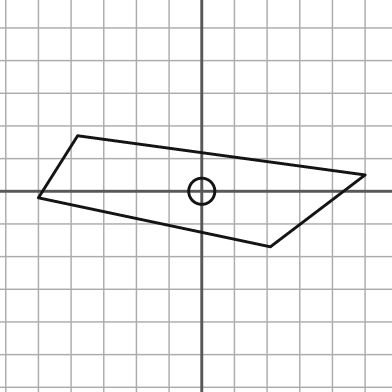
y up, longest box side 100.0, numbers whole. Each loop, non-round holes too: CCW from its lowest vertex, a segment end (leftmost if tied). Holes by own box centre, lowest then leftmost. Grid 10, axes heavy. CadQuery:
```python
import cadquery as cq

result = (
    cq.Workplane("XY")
    .moveTo(21.0, -17.0)
    .lineTo(50.0, 5.0)
    .lineTo(-38.0, 17.0)
    .lineTo(-50.0, -2.0)
    .close()
    .moveTo(0.0, 0.0)
    .circle(4.0)
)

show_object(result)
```